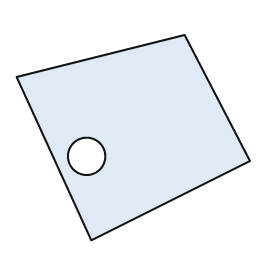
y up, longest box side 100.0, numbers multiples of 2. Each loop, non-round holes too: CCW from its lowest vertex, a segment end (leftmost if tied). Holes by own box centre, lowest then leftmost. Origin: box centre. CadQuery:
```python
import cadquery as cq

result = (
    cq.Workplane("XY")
    .moveTo(-18.0, -44.0)
    .lineTo(50.0, -10.0)
    .lineTo(22.0, 44.0)
    .lineTo(-50.0, 26.0)
    .close()
    .moveTo(-20.0, -8.0)
    .circle(8.0)
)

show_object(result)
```